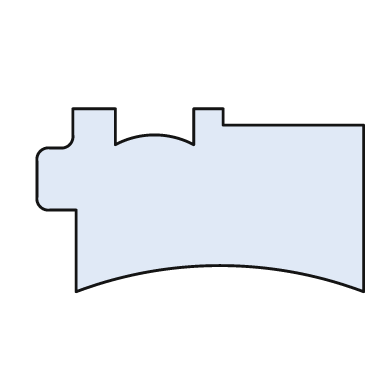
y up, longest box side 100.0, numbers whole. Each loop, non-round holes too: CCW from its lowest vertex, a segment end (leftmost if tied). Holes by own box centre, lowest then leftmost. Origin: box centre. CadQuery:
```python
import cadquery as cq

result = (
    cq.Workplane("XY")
    .moveTo(-38.0, -28.0)
    .threePointArc((6.0, -20.0), (50.0, -28.0))
    .lineTo(50.0, 23.0)
    .lineTo(7.0, 23.0)
    .lineTo(7.0, 28.0)
    .lineTo(-2.0, 28.0)
    .lineTo(-2.0, 17.0)
    .threePointArc((-14.0, 20.0), (-26.0, 17.0))
    .lineTo(-26.0, 28.0)
    .lineTo(-39.0, 28.0)
    .lineTo(-39.0, 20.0)
    .threePointArc((-40.0, 17.0), (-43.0, 16.0))
    .lineTo(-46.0, 16.0)
    .threePointArc((-49.0, 15.0), (-50.0, 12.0))
    .lineTo(-50.0, 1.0)
    .threePointArc((-49.0, -2.0), (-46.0, -3.0))
    .lineTo(-38.0, -3.0)
    .close()
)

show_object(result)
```